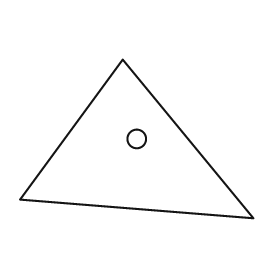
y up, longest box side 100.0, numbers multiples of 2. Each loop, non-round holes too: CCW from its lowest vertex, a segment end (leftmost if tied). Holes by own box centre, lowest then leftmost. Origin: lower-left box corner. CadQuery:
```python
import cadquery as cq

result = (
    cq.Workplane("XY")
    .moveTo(100.0, 0.0)
    .lineTo(44.0, 68.0)
    .lineTo(0.0, 8.0)
    .close()
    .moveTo(50.0, 34.0)
    .circle(4.0)
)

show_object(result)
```